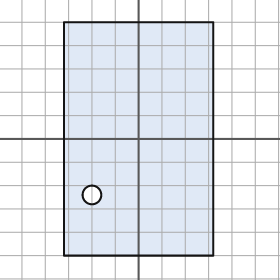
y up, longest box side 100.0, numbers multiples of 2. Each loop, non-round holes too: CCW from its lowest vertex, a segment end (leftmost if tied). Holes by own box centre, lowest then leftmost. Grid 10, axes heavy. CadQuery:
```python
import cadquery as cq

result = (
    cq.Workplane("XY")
    .moveTo(-32.0, -50.0)
    .lineTo(32.0, -50.0)
    .lineTo(32.0, 50.0)
    .lineTo(-32.0, 50.0)
    .close()
    .moveTo(-20.0, -24.0)
    .circle(4.0)
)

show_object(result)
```